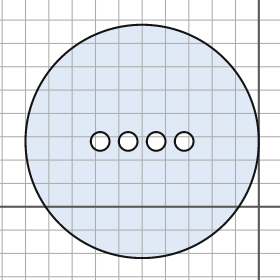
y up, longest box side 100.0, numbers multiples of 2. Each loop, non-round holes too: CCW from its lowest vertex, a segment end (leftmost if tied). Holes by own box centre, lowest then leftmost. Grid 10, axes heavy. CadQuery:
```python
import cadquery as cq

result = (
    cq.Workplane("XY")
    .moveTo(-50.0, 28.0)
    .circle(50.0)
    .moveTo(-68.0, 28.0)
    .circle(4.0)
    .moveTo(-56.0, 28.0)
    .circle(4.0)
    .moveTo(-44.0, 28.0)
    .circle(4.0)
    .moveTo(-32.0, 28.0)
    .circle(4.0)
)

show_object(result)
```